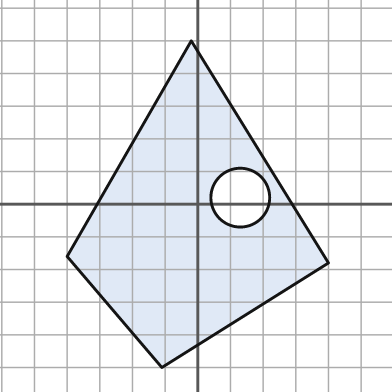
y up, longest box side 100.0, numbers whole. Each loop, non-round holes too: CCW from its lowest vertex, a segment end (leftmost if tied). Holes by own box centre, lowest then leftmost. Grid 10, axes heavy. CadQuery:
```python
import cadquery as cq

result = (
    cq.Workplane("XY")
    .moveTo(-11.0, -50.0)
    .lineTo(40.0, -18.0)
    .lineTo(-2.0, 50.0)
    .lineTo(-40.0, -16.0)
    .close()
    .moveTo(13.0, 2.0)
    .circle(9.0)
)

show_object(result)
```